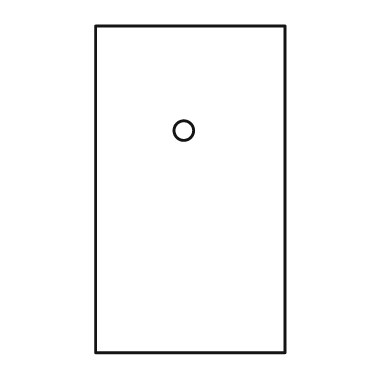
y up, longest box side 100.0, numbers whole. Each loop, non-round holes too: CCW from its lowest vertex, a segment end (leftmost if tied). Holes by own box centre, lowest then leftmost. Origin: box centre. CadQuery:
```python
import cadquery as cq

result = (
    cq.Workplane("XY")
    .moveTo(-29.0, -50.0)
    .lineTo(29.0, -50.0)
    .lineTo(29.0, 50.0)
    .lineTo(-29.0, 50.0)
    .close()
    .moveTo(-2.0, 18.0)
    .circle(3.0)
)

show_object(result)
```